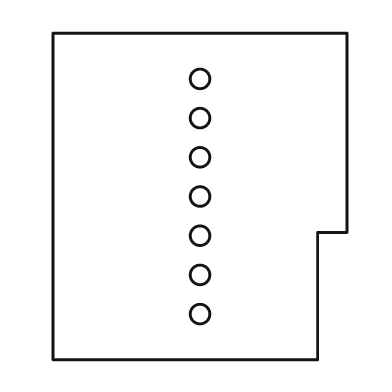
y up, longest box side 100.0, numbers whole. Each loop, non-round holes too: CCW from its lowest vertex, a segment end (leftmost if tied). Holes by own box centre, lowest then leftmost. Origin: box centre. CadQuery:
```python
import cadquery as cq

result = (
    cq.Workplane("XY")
    .moveTo(-45.0, -50.0)
    .lineTo(36.0, -50.0)
    .lineTo(36.0, -11.0)
    .lineTo(45.0, -11.0)
    .lineTo(45.0, 50.0)
    .lineTo(-45.0, 50.0)
    .close()
    .moveTo(0.0, -36.0)
    .circle(3.0)
    .moveTo(0.0, -24.0)
    .circle(3.0)
    .moveTo(0.0, -12.0)
    .circle(3.0)
    .moveTo(0.0, 0.0)
    .circle(3.0)
    .moveTo(0.0, 12.0)
    .circle(3.0)
    .moveTo(0.0, 24.0)
    .circle(3.0)
    .moveTo(0.0, 36.0)
    .circle(3.0)
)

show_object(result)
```